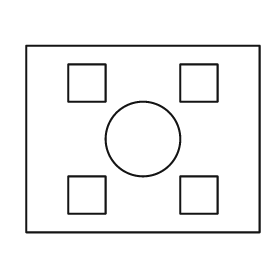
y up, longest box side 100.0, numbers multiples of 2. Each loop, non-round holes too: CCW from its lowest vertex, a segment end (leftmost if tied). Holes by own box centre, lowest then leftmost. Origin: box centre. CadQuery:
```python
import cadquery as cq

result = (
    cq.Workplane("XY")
    .moveTo(-50.0, -40.0)
    .lineTo(50.0, -40.0)
    .lineTo(50.0, 40.0)
    .lineTo(-50.0, 40.0)
    .close()
    .moveTo(-32.0, -32.0)
    .lineTo(-16.0, -32.0)
    .lineTo(-16.0, -16.0)
    .lineTo(-32.0, -16.0)
    .close()
    .moveTo(16.0, -32.0)
    .lineTo(32.0, -32.0)
    .lineTo(32.0, -16.0)
    .lineTo(16.0, -16.0)
    .close()
    .moveTo(0.0, 0.0)
    .circle(16.0)
    .moveTo(-32.0, 16.0)
    .lineTo(-16.0, 16.0)
    .lineTo(-16.0, 32.0)
    .lineTo(-32.0, 32.0)
    .close()
    .moveTo(16.0, 16.0)
    .lineTo(32.0, 16.0)
    .lineTo(32.0, 32.0)
    .lineTo(16.0, 32.0)
    .close()
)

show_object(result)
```